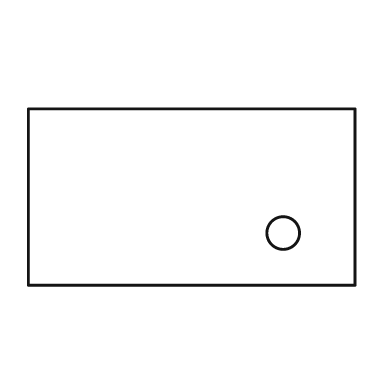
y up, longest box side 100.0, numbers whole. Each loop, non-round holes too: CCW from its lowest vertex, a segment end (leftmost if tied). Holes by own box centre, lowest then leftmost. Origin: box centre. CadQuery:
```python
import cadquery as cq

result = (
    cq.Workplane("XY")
    .moveTo(-50.0, -27.0)
    .lineTo(50.0, -27.0)
    .lineTo(50.0, 27.0)
    .lineTo(-50.0, 27.0)
    .close()
    .moveTo(28.0, -11.0)
    .circle(5.0)
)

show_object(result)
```